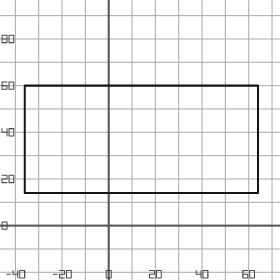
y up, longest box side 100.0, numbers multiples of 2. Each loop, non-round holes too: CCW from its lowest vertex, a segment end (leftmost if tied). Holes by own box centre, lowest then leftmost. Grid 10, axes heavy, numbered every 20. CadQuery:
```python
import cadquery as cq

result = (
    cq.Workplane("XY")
    .moveTo(-36.0, 14.0)
    .lineTo(64.0, 14.0)
    .lineTo(64.0, 60.0)
    .lineTo(-36.0, 60.0)
    .close()
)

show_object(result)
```